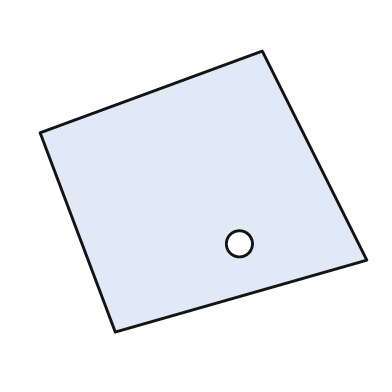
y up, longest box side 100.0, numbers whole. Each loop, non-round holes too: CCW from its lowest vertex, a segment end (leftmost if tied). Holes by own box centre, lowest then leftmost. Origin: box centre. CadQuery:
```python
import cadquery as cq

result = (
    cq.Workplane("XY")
    .moveTo(-27.0, -43.0)
    .lineTo(50.0, -21.0)
    .lineTo(18.0, 43.0)
    .lineTo(-50.0, 18.0)
    .close()
    .moveTo(11.0, -16.0)
    .circle(4.0)
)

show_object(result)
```